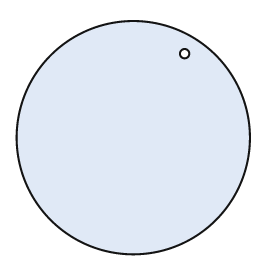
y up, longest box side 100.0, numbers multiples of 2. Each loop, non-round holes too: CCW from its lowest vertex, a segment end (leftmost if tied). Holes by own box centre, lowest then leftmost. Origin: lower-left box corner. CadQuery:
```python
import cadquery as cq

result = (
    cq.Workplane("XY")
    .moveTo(50.0, 50.0)
    .circle(50.0)
    .moveTo(72.0, 86.0)
    .circle(2.0)
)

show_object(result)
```